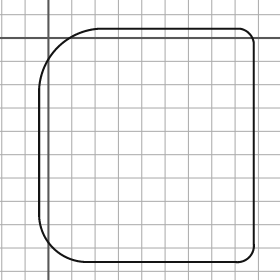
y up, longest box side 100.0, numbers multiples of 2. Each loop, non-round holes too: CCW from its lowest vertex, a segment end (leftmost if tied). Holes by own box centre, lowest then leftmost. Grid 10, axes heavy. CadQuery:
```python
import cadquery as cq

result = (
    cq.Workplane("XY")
    .moveTo(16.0, -96.0)
    .lineTo(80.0, -96.0)
    .threePointArc((86.0, -94.0), (88.0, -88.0))
    .lineTo(88.0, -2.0)
    .threePointArc((86.0, 2.0), (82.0, 4.0))
    .lineTo(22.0, 4.0)
    .threePointArc((4.0, -4.0), (-4.0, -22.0))
    .lineTo(-4.0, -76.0)
    .threePointArc((2.0, -90.0), (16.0, -96.0))
    .close()
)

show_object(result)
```